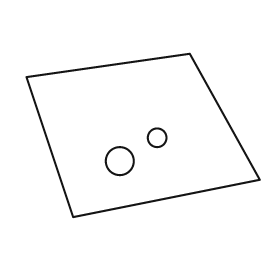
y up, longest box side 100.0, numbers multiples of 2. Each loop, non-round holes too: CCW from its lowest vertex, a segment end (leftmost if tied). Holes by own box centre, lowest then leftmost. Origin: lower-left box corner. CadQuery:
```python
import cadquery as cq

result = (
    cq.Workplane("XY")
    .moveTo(20.0, 0.0)
    .lineTo(100.0, 16.0)
    .lineTo(70.0, 70.0)
    .lineTo(0.0, 60.0)
    .close()
    .moveTo(40.0, 24.0)
    .circle(6.0)
    .moveTo(56.0, 34.0)
    .circle(4.0)
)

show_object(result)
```